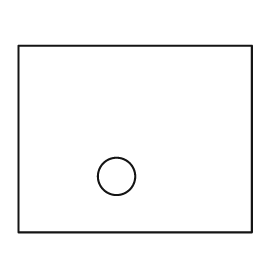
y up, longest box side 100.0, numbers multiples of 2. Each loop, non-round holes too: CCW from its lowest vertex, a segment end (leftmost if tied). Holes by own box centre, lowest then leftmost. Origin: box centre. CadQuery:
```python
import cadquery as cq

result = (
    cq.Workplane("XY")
    .moveTo(-50.0, -40.0)
    .lineTo(50.0, -40.0)
    .lineTo(50.0, 40.0)
    .lineTo(-50.0, 40.0)
    .close()
    .moveTo(-8.0, -16.0)
    .circle(8.0)
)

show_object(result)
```